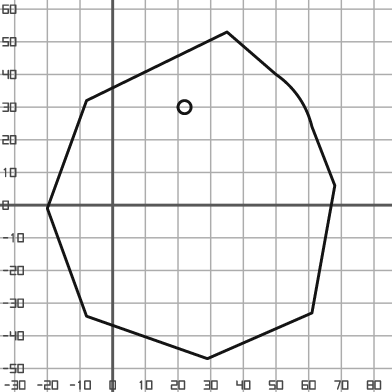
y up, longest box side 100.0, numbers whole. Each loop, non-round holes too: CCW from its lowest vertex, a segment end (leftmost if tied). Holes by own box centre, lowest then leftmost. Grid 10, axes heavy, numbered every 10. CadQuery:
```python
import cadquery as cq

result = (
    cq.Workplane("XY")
    .moveTo(29.0, -47.0)
    .lineTo(61.0, -33.0)
    .lineTo(68.0, 6.0)
    .lineTo(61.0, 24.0)
    .threePointArc((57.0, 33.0), (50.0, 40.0))
    .lineTo(35.0, 53.0)
    .lineTo(-8.0, 32.0)
    .lineTo(-20.0, -1.0)
    .lineTo(-8.0, -34.0)
    .close()
    .moveTo(22.0, 30.0)
    .circle(2.0)
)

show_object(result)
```